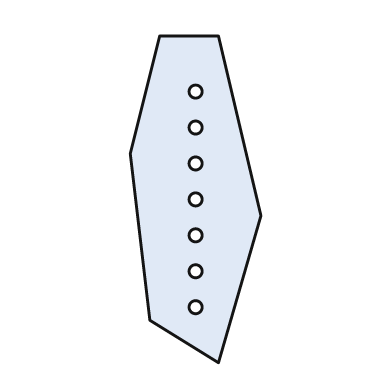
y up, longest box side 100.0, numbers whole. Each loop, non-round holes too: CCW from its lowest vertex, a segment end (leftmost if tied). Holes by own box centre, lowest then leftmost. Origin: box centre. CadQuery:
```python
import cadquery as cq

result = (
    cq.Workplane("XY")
    .moveTo(7.0, -50.0)
    .lineTo(20.0, -5.0)
    .lineTo(7.0, 50.0)
    .lineTo(-11.0, 50.0)
    .lineTo(-20.0, 14.0)
    .lineTo(-14.0, -37.0)
    .close()
    .moveTo(0.0, -33.0)
    .circle(2.0)
    .moveTo(0.0, -22.0)
    .circle(2.0)
    .moveTo(0.0, -11.0)
    .circle(2.0)
    .moveTo(0.0, 0.0)
    .circle(2.0)
    .moveTo(0.0, 11.0)
    .circle(2.0)
    .moveTo(0.0, 22.0)
    .circle(2.0)
    .moveTo(0.0, 33.0)
    .circle(2.0)
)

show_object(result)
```